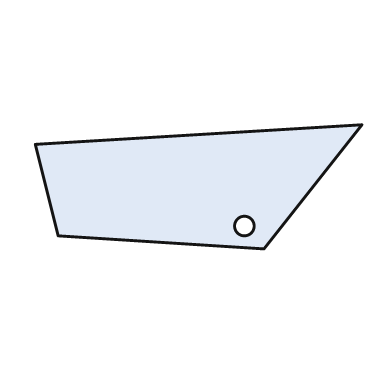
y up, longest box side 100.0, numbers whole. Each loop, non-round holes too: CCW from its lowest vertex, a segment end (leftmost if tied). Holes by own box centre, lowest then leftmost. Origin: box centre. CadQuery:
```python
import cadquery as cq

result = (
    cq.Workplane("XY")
    .moveTo(20.0, -19.0)
    .lineTo(50.0, 19.0)
    .lineTo(-50.0, 13.0)
    .lineTo(-43.0, -15.0)
    .close()
    .moveTo(14.0, -12.0)
    .circle(3.0)
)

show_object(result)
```